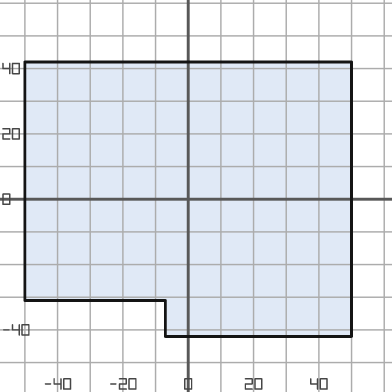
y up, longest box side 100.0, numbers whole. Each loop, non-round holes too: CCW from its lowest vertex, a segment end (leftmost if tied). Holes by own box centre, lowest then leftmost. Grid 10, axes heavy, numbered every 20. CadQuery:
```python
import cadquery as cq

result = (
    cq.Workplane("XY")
    .moveTo(-7.0, -42.0)
    .lineTo(50.0, -42.0)
    .lineTo(50.0, 42.0)
    .lineTo(-50.0, 42.0)
    .lineTo(-50.0, -31.0)
    .lineTo(-7.0, -31.0)
    .close()
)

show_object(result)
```